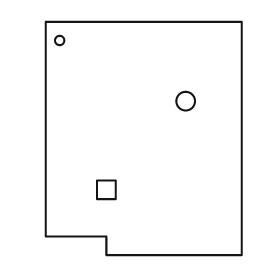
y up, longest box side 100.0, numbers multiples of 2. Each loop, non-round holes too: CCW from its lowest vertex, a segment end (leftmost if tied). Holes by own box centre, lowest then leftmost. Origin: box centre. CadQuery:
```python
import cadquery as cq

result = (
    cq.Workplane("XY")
    .moveTo(-16.0, -50.0)
    .lineTo(42.0, -50.0)
    .lineTo(42.0, 50.0)
    .lineTo(-42.0, 50.0)
    .lineTo(-42.0, -42.0)
    .lineTo(-16.0, -42.0)
    .close()
    .moveTo(-20.0, -26.0)
    .lineTo(-12.0, -26.0)
    .lineTo(-12.0, -18.0)
    .lineTo(-20.0, -18.0)
    .close()
    .moveTo(18.0, 16.0)
    .circle(4.0)
    .moveTo(-36.0, 42.0)
    .circle(2.0)
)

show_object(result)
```